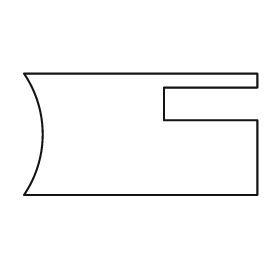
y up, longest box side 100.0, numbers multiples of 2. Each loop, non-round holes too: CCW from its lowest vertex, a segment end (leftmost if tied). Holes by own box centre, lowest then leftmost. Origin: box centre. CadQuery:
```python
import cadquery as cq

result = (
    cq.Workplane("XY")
    .moveTo(-50.0, -26.0)
    .lineTo(50.0, -26.0)
    .lineTo(50.0, 6.0)
    .lineTo(10.0, 6.0)
    .lineTo(10.0, 20.0)
    .lineTo(50.0, 20.0)
    .lineTo(50.0, 26.0)
    .lineTo(-50.0, 26.0)
    .threePointArc((-42.0, 0.0), (-50.0, -26.0))
    .close()
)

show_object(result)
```